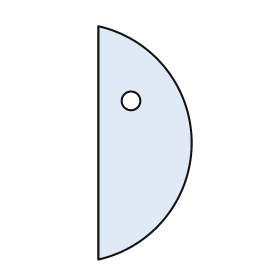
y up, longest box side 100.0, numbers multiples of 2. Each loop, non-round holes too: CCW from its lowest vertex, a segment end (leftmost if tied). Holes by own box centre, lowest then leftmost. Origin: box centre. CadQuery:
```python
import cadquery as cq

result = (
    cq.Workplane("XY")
    .moveTo(-20.0, -50.0)
    .threePointArc((20.0, 0.0), (-20.0, 50.0))
    .close()
    .moveTo(-6.0, 18.0)
    .circle(4.0)
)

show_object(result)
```